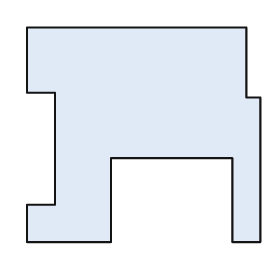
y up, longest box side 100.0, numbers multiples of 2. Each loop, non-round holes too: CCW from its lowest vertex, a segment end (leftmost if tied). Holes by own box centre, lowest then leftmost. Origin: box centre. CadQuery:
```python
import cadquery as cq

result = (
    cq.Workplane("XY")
    .moveTo(-50.0, -46.0)
    .lineTo(-14.0, -46.0)
    .lineTo(-14.0, -10.0)
    .lineTo(38.0, -10.0)
    .lineTo(38.0, -46.0)
    .lineTo(50.0, -46.0)
    .lineTo(50.0, 16.0)
    .lineTo(44.0, 16.0)
    .lineTo(44.0, 46.0)
    .lineTo(-50.0, 46.0)
    .lineTo(-50.0, 18.0)
    .lineTo(-38.0, 18.0)
    .lineTo(-38.0, -30.0)
    .lineTo(-50.0, -30.0)
    .close()
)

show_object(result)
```